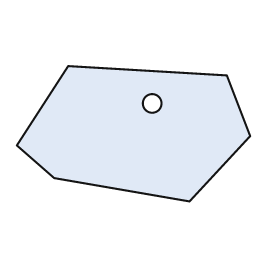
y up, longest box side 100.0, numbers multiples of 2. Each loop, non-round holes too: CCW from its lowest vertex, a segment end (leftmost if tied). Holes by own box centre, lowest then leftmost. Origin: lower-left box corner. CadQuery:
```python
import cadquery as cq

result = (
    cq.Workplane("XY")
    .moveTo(74.0, 0.0)
    .lineTo(100.0, 28.0)
    .lineTo(90.0, 54.0)
    .lineTo(22.0, 58.0)
    .lineTo(0.0, 24.0)
    .lineTo(16.0, 10.0)
    .close()
    .moveTo(58.0, 42.0)
    .circle(4.0)
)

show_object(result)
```